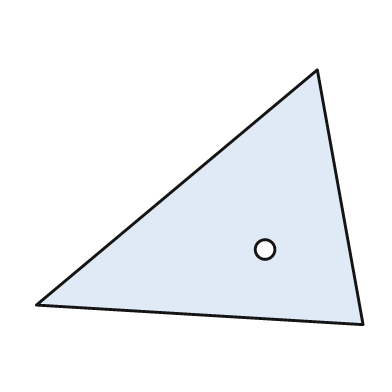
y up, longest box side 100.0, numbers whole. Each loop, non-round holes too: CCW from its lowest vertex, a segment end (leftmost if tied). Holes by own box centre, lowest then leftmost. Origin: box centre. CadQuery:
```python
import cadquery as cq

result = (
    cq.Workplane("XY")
    .moveTo(50.0, -39.0)
    .lineTo(36.0, 39.0)
    .lineTo(-50.0, -33.0)
    .close()
    .moveTo(20.0, -16.0)
    .circle(3.0)
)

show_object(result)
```